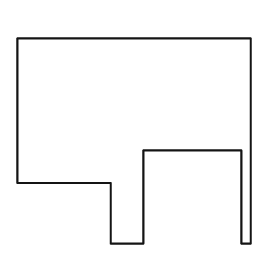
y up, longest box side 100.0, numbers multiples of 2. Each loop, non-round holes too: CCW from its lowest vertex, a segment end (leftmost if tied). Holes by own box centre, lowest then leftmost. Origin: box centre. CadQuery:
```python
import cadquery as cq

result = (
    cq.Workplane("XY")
    .moveTo(-10.0, -44.0)
    .lineTo(4.0, -44.0)
    .lineTo(4.0, -4.0)
    .lineTo(46.0, -4.0)
    .lineTo(46.0, -44.0)
    .lineTo(50.0, -44.0)
    .lineTo(50.0, 44.0)
    .lineTo(-50.0, 44.0)
    .lineTo(-50.0, -18.0)
    .lineTo(-10.0, -18.0)
    .close()
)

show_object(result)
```